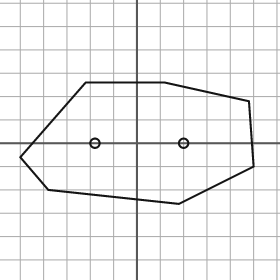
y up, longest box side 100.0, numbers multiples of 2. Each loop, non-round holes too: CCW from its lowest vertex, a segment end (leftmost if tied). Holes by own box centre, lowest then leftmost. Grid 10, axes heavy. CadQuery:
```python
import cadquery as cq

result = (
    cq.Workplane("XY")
    .moveTo(18.0, -26.0)
    .lineTo(50.0, -10.0)
    .lineTo(48.0, 18.0)
    .lineTo(12.0, 26.0)
    .lineTo(-22.0, 26.0)
    .lineTo(-50.0, -6.0)
    .lineTo(-38.0, -20.0)
    .close()
    .moveTo(-18.0, 0.0)
    .circle(2.0)
    .moveTo(20.0, 0.0)
    .circle(2.0)
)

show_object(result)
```